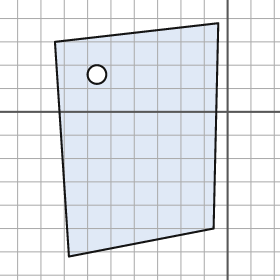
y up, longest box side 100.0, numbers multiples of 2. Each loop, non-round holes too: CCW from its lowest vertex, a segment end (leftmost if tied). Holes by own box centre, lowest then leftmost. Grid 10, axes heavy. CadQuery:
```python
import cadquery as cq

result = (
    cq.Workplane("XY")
    .moveTo(-68.0, -62.0)
    .lineTo(-6.0, -50.0)
    .lineTo(-4.0, 38.0)
    .lineTo(-74.0, 30.0)
    .close()
    .moveTo(-56.0, 16.0)
    .circle(4.0)
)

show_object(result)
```